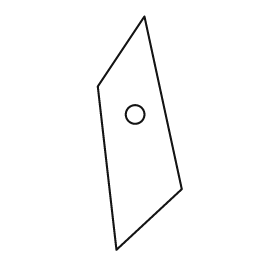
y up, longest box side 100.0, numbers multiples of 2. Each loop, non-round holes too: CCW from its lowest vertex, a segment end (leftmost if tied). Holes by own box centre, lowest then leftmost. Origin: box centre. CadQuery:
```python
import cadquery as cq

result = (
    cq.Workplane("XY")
    .moveTo(-10.0, -50.0)
    .lineTo(18.0, -24.0)
    .lineTo(2.0, 50.0)
    .lineTo(-18.0, 20.0)
    .close()
    .moveTo(-2.0, 8.0)
    .circle(4.0)
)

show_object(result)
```